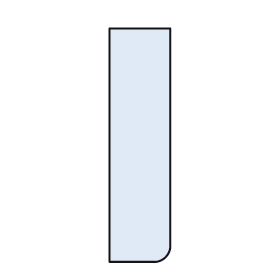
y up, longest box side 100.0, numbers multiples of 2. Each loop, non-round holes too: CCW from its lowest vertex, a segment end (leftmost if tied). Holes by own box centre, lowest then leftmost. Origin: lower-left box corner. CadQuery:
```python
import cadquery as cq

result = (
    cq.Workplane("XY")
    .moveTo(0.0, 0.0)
    .lineTo(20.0, 0.0)
    .threePointArc((24.0, 2.0), (26.0, 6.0))
    .lineTo(26.0, 100.0)
    .lineTo(0.0, 100.0)
    .close()
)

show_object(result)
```